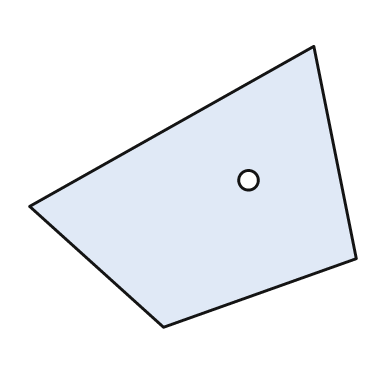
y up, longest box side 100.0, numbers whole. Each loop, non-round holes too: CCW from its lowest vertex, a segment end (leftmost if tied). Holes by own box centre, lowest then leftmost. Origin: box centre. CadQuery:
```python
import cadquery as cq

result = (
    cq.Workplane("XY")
    .moveTo(-9.0, -43.0)
    .lineTo(50.0, -22.0)
    .lineTo(37.0, 43.0)
    .lineTo(-50.0, -6.0)
    .close()
    .moveTo(17.0, 2.0)
    .circle(3.0)
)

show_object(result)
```